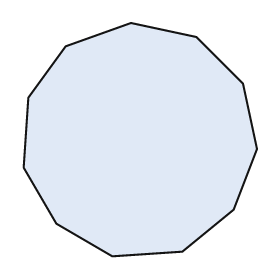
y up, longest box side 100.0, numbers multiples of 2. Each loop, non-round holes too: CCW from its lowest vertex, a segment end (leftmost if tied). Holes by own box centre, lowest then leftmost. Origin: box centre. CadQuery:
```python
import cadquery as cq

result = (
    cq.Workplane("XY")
    .moveTo(-12.0, -50.0)
    .lineTo(18.0, -48.0)
    .lineTo(40.0, -30.0)
    .lineTo(50.0, -4.0)
    .lineTo(44.0, 24.0)
    .lineTo(24.0, 44.0)
    .lineTo(-4.0, 50.0)
    .lineTo(-32.0, 40.0)
    .lineTo(-48.0, 18.0)
    .lineTo(-50.0, -12.0)
    .lineTo(-36.0, -36.0)
    .close()
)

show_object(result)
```